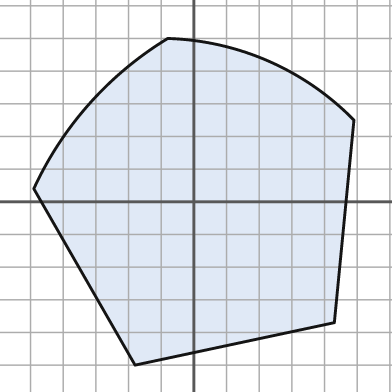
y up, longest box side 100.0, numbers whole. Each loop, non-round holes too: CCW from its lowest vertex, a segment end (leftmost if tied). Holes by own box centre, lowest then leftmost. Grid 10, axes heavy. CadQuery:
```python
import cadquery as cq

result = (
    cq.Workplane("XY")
    .moveTo(-18.0, -50.0)
    .lineTo(43.0, -37.0)
    .lineTo(49.0, 25.0)
    .threePointArc((23.0, 43.0), (-8.0, 50.0))
    .threePointArc((-32.0, 30.0), (-49.0, 4.0))
    .close()
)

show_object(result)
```